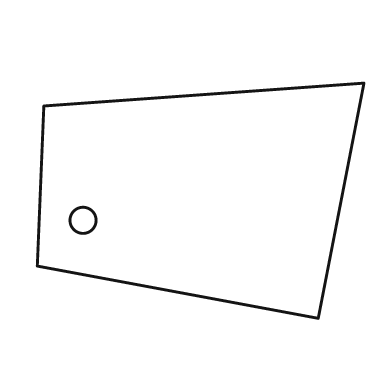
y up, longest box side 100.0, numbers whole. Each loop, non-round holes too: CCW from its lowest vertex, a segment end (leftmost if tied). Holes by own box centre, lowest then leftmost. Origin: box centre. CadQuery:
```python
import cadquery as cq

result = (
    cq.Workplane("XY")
    .moveTo(36.0, -36.0)
    .lineTo(50.0, 36.0)
    .lineTo(-48.0, 29.0)
    .lineTo(-50.0, -20.0)
    .close()
    .moveTo(-36.0, -6.0)
    .circle(4.0)
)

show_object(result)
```